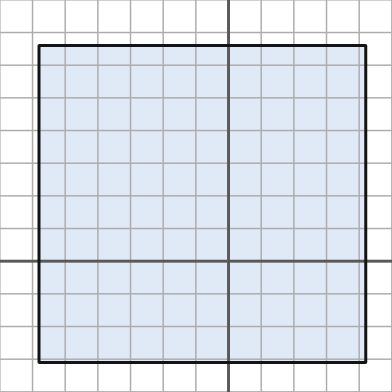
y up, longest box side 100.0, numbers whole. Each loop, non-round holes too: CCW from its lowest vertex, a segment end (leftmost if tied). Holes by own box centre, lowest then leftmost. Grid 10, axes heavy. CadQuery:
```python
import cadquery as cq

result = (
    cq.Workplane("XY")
    .moveTo(-58.0, -31.0)
    .lineTo(42.0, -31.0)
    .lineTo(42.0, 66.0)
    .lineTo(-58.0, 66.0)
    .close()
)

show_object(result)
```